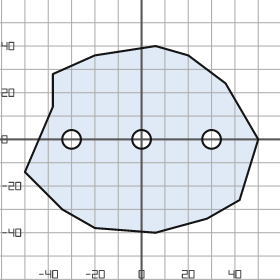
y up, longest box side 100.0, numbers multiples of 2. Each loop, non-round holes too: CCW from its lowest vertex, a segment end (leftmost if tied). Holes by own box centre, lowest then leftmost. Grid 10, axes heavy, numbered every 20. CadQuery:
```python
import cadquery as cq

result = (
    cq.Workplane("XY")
    .moveTo(6.0, -40.0)
    .lineTo(28.0, -34.0)
    .lineTo(42.0, -26.0)
    .lineTo(50.0, 0.0)
    .lineTo(36.0, 24.0)
    .lineTo(20.0, 36.0)
    .lineTo(6.0, 40.0)
    .lineTo(-20.0, 36.0)
    .lineTo(-38.0, 28.0)
    .lineTo(-38.0, 14.0)
    .lineTo(-50.0, -14.0)
    .lineTo(-34.0, -30.0)
    .lineTo(-20.0, -38.0)
    .close()
    .moveTo(-30.0, 0.0)
    .circle(4.0)
    .moveTo(0.0, 0.0)
    .circle(4.0)
    .moveTo(30.0, 0.0)
    .circle(4.0)
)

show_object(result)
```